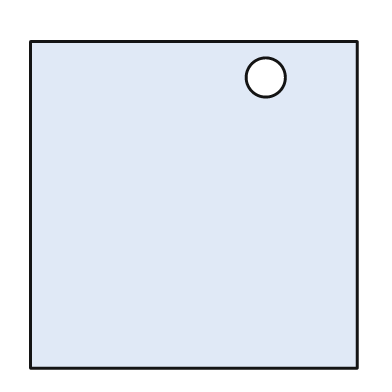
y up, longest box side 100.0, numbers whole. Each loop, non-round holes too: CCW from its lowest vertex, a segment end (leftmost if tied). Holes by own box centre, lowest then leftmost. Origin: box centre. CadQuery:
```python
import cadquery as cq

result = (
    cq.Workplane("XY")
    .moveTo(-50.0, -50.0)
    .lineTo(50.0, -50.0)
    .lineTo(50.0, 50.0)
    .lineTo(-50.0, 50.0)
    .close()
    .moveTo(22.0, 39.0)
    .circle(6.0)
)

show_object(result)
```